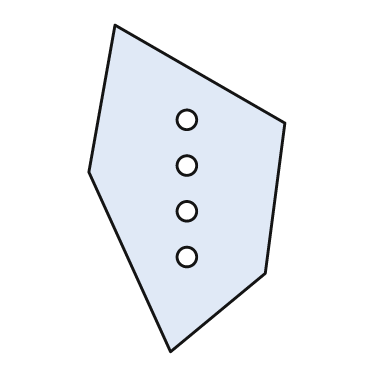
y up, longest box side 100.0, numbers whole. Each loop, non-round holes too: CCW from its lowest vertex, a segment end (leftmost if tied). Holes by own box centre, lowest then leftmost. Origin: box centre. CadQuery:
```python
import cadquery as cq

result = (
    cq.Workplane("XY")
    .moveTo(-5.0, -50.0)
    .lineTo(24.0, -26.0)
    .lineTo(30.0, 20.0)
    .lineTo(-22.0, 50.0)
    .lineTo(-30.0, 5.0)
    .close()
    .moveTo(0.0, -21.0)
    .circle(3.0)
    .moveTo(0.0, -7.0)
    .circle(3.0)
    .moveTo(0.0, 7.0)
    .circle(3.0)
    .moveTo(0.0, 21.0)
    .circle(3.0)
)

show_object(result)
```